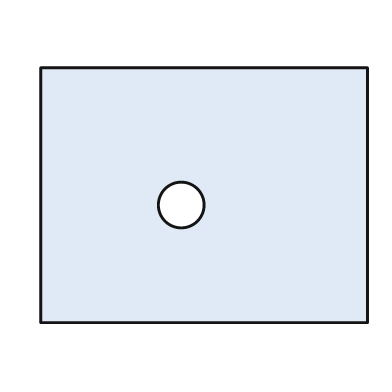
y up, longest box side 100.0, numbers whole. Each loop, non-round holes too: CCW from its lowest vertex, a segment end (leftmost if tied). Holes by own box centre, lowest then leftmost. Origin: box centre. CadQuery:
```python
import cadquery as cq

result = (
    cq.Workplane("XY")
    .moveTo(-50.0, -39.0)
    .lineTo(50.0, -39.0)
    .lineTo(50.0, 39.0)
    .lineTo(-50.0, 39.0)
    .close()
    .moveTo(-7.0, -3.0)
    .circle(7.0)
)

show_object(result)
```